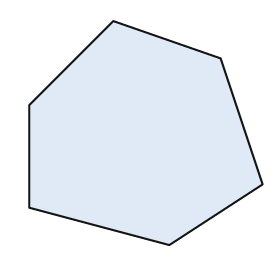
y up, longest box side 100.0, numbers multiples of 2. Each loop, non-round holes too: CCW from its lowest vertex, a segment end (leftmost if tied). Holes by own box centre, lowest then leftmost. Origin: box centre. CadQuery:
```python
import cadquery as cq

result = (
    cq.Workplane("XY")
    .moveTo(10.0, -48.0)
    .lineTo(50.0, -22.0)
    .lineTo(32.0, 32.0)
    .lineTo(-14.0, 48.0)
    .lineTo(-50.0, 12.0)
    .lineTo(-50.0, -32.0)
    .close()
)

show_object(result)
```